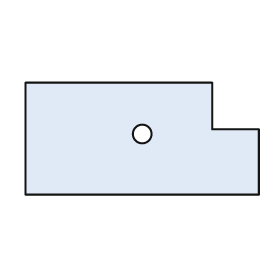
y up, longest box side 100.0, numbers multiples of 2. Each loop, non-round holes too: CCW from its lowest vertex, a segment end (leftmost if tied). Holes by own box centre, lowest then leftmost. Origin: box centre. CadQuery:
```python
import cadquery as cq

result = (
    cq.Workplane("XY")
    .moveTo(-50.0, -24.0)
    .lineTo(50.0, -24.0)
    .lineTo(50.0, 4.0)
    .lineTo(30.0, 4.0)
    .lineTo(30.0, 24.0)
    .lineTo(-50.0, 24.0)
    .close()
    .moveTo(0.0, 2.0)
    .circle(4.0)
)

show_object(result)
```